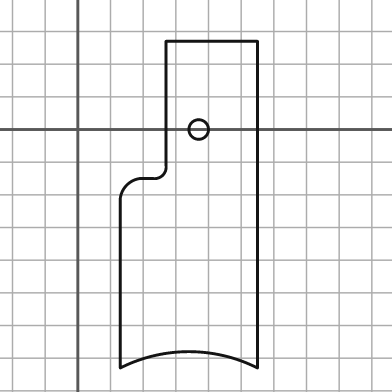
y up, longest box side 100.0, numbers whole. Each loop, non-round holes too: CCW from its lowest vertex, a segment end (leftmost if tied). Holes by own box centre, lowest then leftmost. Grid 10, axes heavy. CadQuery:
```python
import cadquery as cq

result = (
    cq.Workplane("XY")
    .moveTo(13.0, -73.0)
    .threePointArc((34.0, -68.0), (55.0, -73.0))
    .lineTo(55.0, 27.0)
    .lineTo(27.0, 27.0)
    .lineTo(27.0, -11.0)
    .threePointArc((26.0, -14.0), (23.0, -15.0))
    .lineTo(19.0, -15.0)
    .threePointArc((15.0, -17.0), (13.0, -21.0))
    .close()
    .moveTo(37.0, 0.0)
    .circle(3.0)
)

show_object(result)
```